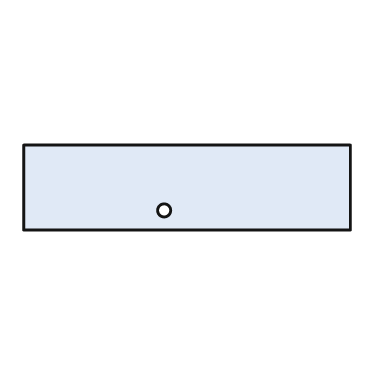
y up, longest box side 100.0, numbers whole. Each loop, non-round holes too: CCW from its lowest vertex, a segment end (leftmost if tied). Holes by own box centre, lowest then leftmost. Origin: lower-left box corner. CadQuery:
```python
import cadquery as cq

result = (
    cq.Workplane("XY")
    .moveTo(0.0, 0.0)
    .lineTo(100.0, 0.0)
    .lineTo(100.0, 26.0)
    .lineTo(0.0, 26.0)
    .close()
    .moveTo(43.0, 6.0)
    .circle(2.0)
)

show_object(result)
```